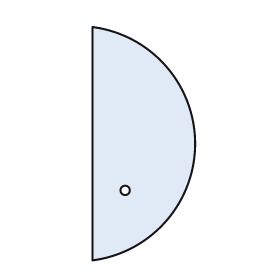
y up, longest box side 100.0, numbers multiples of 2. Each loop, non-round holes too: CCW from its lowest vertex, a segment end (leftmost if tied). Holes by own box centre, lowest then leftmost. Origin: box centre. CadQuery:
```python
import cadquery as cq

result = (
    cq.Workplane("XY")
    .moveTo(-22.0, -50.0)
    .threePointArc((22.0, 0.0), (-22.0, 50.0))
    .close()
    .moveTo(-8.0, -20.0)
    .circle(2.0)
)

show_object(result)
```